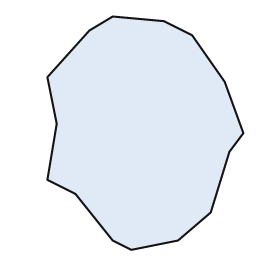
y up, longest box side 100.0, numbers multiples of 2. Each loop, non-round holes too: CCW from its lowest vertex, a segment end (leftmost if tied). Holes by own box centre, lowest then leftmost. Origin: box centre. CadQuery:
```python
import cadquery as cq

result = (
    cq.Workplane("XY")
    .moveTo(-6.0, -50.0)
    .lineTo(14.0, -46.0)
    .lineTo(28.0, -34.0)
    .lineTo(36.0, -8.0)
    .lineTo(42.0, 0.0)
    .lineTo(34.0, 22.0)
    .lineTo(20.0, 42.0)
    .lineTo(8.0, 48.0)
    .lineTo(-14.0, 50.0)
    .lineTo(-24.0, 44.0)
    .lineTo(-42.0, 24.0)
    .lineTo(-38.0, 4.0)
    .lineTo(-42.0, -20.0)
    .lineTo(-30.0, -26.0)
    .lineTo(-14.0, -46.0)
    .close()
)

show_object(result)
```